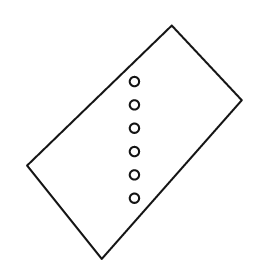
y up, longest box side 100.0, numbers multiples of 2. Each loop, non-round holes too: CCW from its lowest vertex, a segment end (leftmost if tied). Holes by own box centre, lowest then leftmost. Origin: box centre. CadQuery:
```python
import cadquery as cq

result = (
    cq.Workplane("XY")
    .moveTo(-14.0, -50.0)
    .lineTo(46.0, 18.0)
    .lineTo(16.0, 50.0)
    .lineTo(-46.0, -10.0)
    .close()
    .moveTo(0.0, -24.0)
    .circle(2.0)
    .moveTo(0.0, -14.0)
    .circle(2.0)
    .moveTo(0.0, -4.0)
    .circle(2.0)
    .moveTo(0.0, 6.0)
    .circle(2.0)
    .moveTo(0.0, 16.0)
    .circle(2.0)
    .moveTo(0.0, 26.0)
    .circle(2.0)
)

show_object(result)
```